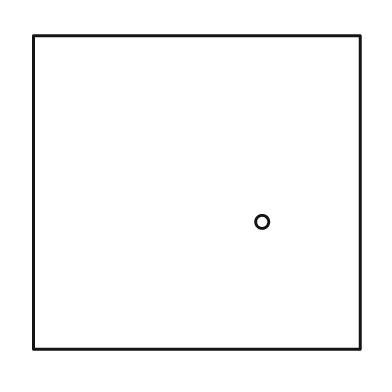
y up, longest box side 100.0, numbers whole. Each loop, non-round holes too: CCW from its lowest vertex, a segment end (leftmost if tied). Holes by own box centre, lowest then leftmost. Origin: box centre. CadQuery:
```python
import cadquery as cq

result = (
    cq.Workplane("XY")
    .moveTo(-50.0, -48.0)
    .lineTo(50.0, -48.0)
    .lineTo(50.0, 48.0)
    .lineTo(-50.0, 48.0)
    .close()
    .moveTo(20.0, -9.0)
    .circle(2.0)
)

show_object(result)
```